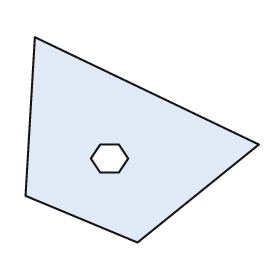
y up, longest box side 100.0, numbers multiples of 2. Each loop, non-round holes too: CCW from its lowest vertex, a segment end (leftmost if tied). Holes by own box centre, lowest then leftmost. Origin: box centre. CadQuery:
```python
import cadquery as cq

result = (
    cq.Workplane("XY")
    .moveTo(-2.0, -44.0)
    .lineTo(50.0, -2.0)
    .lineTo(-46.0, 44.0)
    .lineTo(-50.0, -24.0)
    .close()
    .moveTo(-18.0, -14.0)
    .lineTo(-10.0, -14.0)
    .lineTo(-6.0, -8.0)
    .lineTo(-10.0, -2.0)
    .lineTo(-18.0, -2.0)
    .lineTo(-22.0, -8.0)
    .close()
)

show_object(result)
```